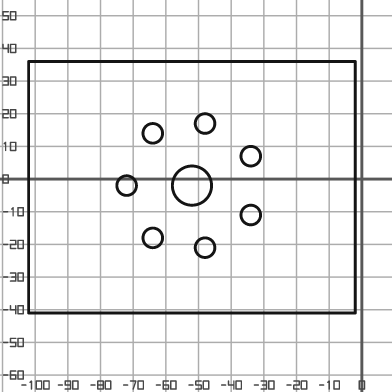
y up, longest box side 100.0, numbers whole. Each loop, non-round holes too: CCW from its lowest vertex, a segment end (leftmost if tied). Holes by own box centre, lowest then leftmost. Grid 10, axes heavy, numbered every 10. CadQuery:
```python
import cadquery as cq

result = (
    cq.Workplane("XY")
    .moveTo(-102.0, -41.0)
    .lineTo(-2.0, -41.0)
    .lineTo(-2.0, 36.0)
    .lineTo(-102.0, 36.0)
    .close()
    .moveTo(-48.0, -21.0)
    .circle(3.0)
    .moveTo(-64.0, -18.0)
    .circle(3.0)
    .moveTo(-34.0, -11.0)
    .circle(3.0)
    .moveTo(-72.0, -2.0)
    .circle(3.0)
    .moveTo(-52.0, -2.0)
    .circle(6.0)
    .moveTo(-34.0, 7.0)
    .circle(3.0)
    .moveTo(-64.0, 14.0)
    .circle(3.0)
    .moveTo(-48.0, 17.0)
    .circle(3.0)
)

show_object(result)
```